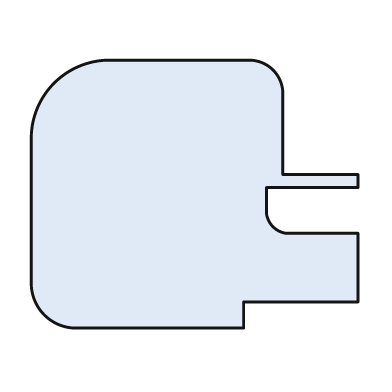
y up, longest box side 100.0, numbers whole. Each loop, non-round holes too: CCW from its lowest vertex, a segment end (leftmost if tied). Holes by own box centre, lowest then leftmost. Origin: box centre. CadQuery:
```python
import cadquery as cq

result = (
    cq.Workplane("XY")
    .moveTo(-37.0, -41.0)
    .lineTo(15.0, -41.0)
    .lineTo(15.0, -33.0)
    .lineTo(50.0, -33.0)
    .lineTo(50.0, -12.0)
    .lineTo(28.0, -12.0)
    .threePointArc((24.0, -10.0), (22.0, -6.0))
    .lineTo(22.0, 2.0)
    .lineTo(50.0, 2.0)
    .lineTo(50.0, 6.0)
    .lineTo(27.0, 6.0)
    .lineTo(27.0, 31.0)
    .threePointArc((24.0, 38.0), (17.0, 41.0))
    .lineTo(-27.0, 41.0)
    .threePointArc((-43.0, 34.0), (-50.0, 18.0))
    .lineTo(-50.0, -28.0)
    .threePointArc((-46.0, -37.0), (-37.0, -41.0))
    .close()
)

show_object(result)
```